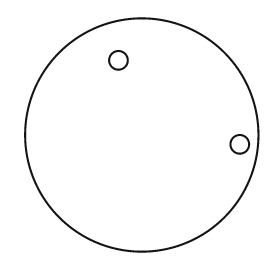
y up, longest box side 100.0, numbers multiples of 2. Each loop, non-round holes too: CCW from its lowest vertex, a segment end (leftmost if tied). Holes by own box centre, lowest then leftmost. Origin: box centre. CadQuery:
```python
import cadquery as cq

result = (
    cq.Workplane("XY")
    .moveTo(0.0, 0.0)
    .circle(50.0)
    .moveTo(42.0, -4.0)
    .circle(4.0)
    .moveTo(-10.0, 32.0)
    .circle(4.0)
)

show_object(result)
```